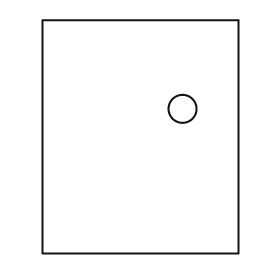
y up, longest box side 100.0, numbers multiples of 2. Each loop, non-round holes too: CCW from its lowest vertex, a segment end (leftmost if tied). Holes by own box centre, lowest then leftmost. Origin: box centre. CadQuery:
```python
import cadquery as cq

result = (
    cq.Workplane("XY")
    .moveTo(-42.0, -50.0)
    .lineTo(42.0, -50.0)
    .lineTo(42.0, 50.0)
    .lineTo(-42.0, 50.0)
    .close()
    .moveTo(18.0, 12.0)
    .circle(6.0)
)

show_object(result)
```